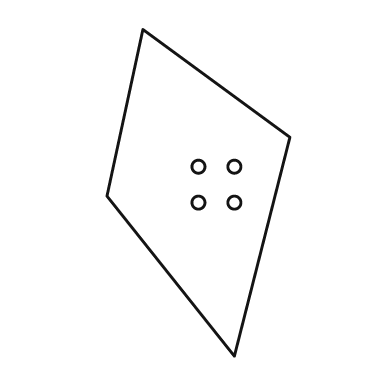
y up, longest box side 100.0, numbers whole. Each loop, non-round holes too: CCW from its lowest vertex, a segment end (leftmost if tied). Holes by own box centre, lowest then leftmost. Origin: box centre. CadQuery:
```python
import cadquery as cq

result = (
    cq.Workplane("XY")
    .moveTo(11.0, -50.0)
    .lineTo(28.0, 17.0)
    .lineTo(-17.0, 50.0)
    .lineTo(-28.0, -1.0)
    .close()
    .moveTo(0.0, -3.0)
    .circle(2.0)
    .moveTo(11.0, -3.0)
    .circle(2.0)
    .moveTo(0.0, 8.0)
    .circle(2.0)
    .moveTo(11.0, 8.0)
    .circle(2.0)
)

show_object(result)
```